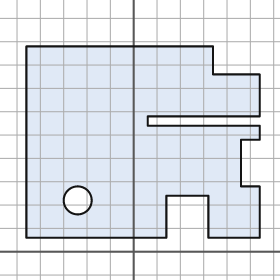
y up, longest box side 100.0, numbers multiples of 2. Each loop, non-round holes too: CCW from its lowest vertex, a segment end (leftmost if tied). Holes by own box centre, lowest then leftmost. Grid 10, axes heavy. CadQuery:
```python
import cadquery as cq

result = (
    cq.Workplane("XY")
    .moveTo(-46.0, 6.0)
    .lineTo(14.0, 6.0)
    .lineTo(14.0, 24.0)
    .lineTo(32.0, 24.0)
    .lineTo(32.0, 6.0)
    .lineTo(54.0, 6.0)
    .lineTo(54.0, 28.0)
    .lineTo(46.0, 28.0)
    .lineTo(46.0, 48.0)
    .lineTo(54.0, 48.0)
    .lineTo(54.0, 54.0)
    .lineTo(6.0, 54.0)
    .lineTo(6.0, 58.0)
    .lineTo(54.0, 58.0)
    .lineTo(54.0, 76.0)
    .lineTo(34.0, 76.0)
    .lineTo(34.0, 88.0)
    .lineTo(-46.0, 88.0)
    .close()
    .moveTo(-24.0, 22.0)
    .circle(6.0)
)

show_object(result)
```